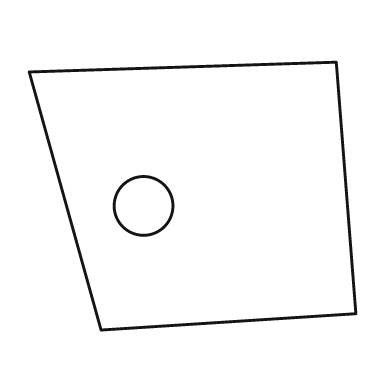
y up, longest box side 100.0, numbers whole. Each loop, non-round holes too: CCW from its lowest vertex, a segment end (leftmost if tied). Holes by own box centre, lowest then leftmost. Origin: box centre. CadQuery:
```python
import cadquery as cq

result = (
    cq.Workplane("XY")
    .moveTo(-28.0, -41.0)
    .lineTo(50.0, -36.0)
    .lineTo(44.0, 41.0)
    .lineTo(-50.0, 38.0)
    .close()
    .moveTo(-15.0, -3.0)
    .circle(9.0)
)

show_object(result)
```